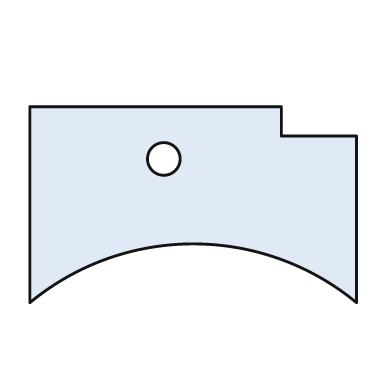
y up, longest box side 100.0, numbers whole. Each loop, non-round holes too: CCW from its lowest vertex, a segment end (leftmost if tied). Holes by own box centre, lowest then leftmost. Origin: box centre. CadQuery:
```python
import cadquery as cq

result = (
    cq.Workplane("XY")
    .moveTo(-50.0, -30.0)
    .threePointArc((0.0, -12.0), (50.0, -30.0))
    .lineTo(50.0, 21.0)
    .lineTo(27.0, 21.0)
    .lineTo(27.0, 30.0)
    .lineTo(-50.0, 30.0)
    .close()
    .moveTo(-9.0, 14.0)
    .circle(5.0)
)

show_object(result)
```